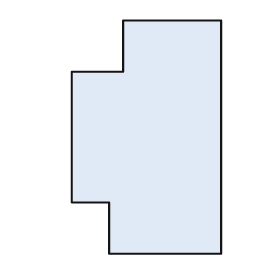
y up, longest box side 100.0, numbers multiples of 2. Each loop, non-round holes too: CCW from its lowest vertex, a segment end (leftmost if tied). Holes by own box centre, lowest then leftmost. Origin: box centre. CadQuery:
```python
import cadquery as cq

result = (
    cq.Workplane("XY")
    .moveTo(-16.0, -50.0)
    .lineTo(32.0, -50.0)
    .lineTo(32.0, 50.0)
    .lineTo(-10.0, 50.0)
    .lineTo(-10.0, 28.0)
    .lineTo(-32.0, 28.0)
    .lineTo(-32.0, -28.0)
    .lineTo(-16.0, -28.0)
    .close()
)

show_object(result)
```